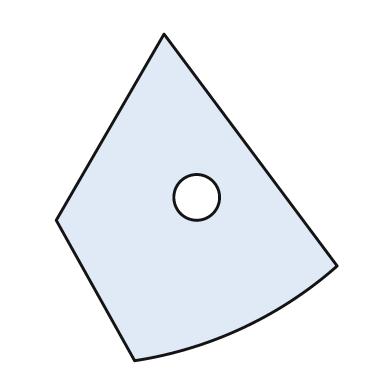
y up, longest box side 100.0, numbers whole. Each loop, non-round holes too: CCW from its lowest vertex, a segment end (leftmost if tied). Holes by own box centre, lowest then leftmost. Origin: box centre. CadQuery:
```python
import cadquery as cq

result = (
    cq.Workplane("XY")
    .moveTo(-19.0, -50.0)
    .threePointArc((14.0, -40.0), (43.0, -21.0))
    .lineTo(-10.0, 50.0)
    .lineTo(-43.0, -7.0)
    .close()
    .moveTo(0.0, 0.0)
    .circle(7.0)
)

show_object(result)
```